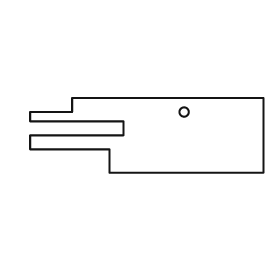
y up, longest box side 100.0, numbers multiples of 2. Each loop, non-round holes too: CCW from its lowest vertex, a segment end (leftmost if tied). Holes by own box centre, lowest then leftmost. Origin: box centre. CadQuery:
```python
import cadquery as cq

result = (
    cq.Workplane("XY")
    .moveTo(-16.0, -16.0)
    .lineTo(50.0, -16.0)
    .lineTo(50.0, 16.0)
    .lineTo(-32.0, 16.0)
    .lineTo(-32.0, 10.0)
    .lineTo(-50.0, 10.0)
    .lineTo(-50.0, 6.0)
    .lineTo(-10.0, 6.0)
    .lineTo(-10.0, 0.0)
    .lineTo(-50.0, 0.0)
    .lineTo(-50.0, -6.0)
    .lineTo(-16.0, -6.0)
    .close()
    .moveTo(16.0, 10.0)
    .circle(2.0)
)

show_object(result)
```